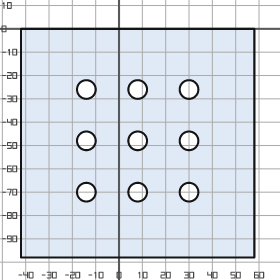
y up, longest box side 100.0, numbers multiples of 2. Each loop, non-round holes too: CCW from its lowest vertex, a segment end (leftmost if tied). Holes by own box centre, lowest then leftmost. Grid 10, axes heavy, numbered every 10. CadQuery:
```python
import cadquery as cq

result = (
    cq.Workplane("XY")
    .moveTo(-42.0, -98.0)
    .lineTo(58.0, -98.0)
    .lineTo(58.0, 0.0)
    .lineTo(-42.0, 0.0)
    .close()
    .moveTo(-14.0, -70.0)
    .circle(4.0)
    .moveTo(8.0, -70.0)
    .circle(4.0)
    .moveTo(30.0, -70.0)
    .circle(4.0)
    .moveTo(-14.0, -48.0)
    .circle(4.0)
    .moveTo(8.0, -48.0)
    .circle(4.0)
    .moveTo(30.0, -48.0)
    .circle(4.0)
    .moveTo(-14.0, -26.0)
    .circle(4.0)
    .moveTo(8.0, -26.0)
    .circle(4.0)
    .moveTo(30.0, -26.0)
    .circle(4.0)
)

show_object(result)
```